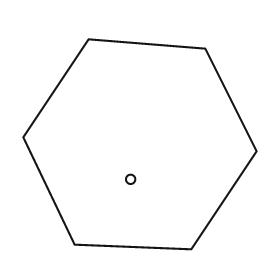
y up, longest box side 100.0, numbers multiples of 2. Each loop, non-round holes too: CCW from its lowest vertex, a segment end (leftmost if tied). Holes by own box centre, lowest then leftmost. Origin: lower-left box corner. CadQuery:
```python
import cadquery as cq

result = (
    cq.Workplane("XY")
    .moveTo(72.0, 0.0)
    .lineTo(100.0, 42.0)
    .lineTo(78.0, 86.0)
    .lineTo(28.0, 90.0)
    .lineTo(0.0, 48.0)
    .lineTo(22.0, 2.0)
    .close()
    .moveTo(46.0, 30.0)
    .circle(2.0)
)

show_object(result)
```